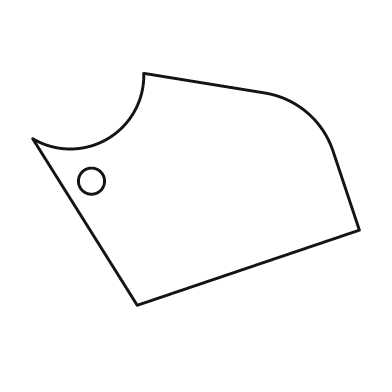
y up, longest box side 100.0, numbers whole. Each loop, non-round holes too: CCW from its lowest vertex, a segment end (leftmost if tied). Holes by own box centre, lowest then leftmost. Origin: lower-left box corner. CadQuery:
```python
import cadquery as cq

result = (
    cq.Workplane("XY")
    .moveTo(32.0, 0.0)
    .lineTo(100.0, 23.0)
    .lineTo(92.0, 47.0)
    .threePointArc((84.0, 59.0), (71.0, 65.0))
    .lineTo(34.0, 71.0)
    .threePointArc((23.0, 51.0), (0.0, 51.0))
    .close()
    .moveTo(18.0, 38.0)
    .circle(4.0)
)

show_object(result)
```